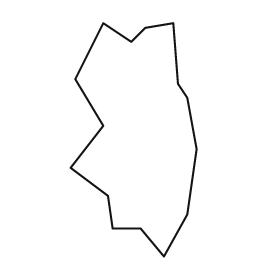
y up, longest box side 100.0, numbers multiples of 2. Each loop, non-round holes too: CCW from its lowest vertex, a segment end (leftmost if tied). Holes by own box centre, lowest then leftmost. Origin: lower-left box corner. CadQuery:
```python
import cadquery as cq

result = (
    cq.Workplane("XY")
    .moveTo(40.0, 0.0)
    .lineTo(50.0, 18.0)
    .lineTo(54.0, 46.0)
    .lineTo(50.0, 68.0)
    .lineTo(46.0, 74.0)
    .lineTo(44.0, 100.0)
    .lineTo(32.0, 98.0)
    .lineTo(26.0, 92.0)
    .lineTo(14.0, 100.0)
    .lineTo(2.0, 76.0)
    .lineTo(14.0, 56.0)
    .lineTo(0.0, 38.0)
    .lineTo(16.0, 26.0)
    .lineTo(18.0, 12.0)
    .lineTo(30.0, 12.0)
    .close()
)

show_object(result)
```